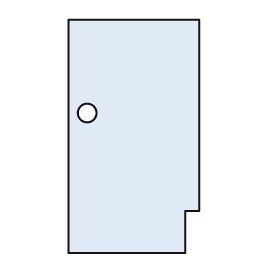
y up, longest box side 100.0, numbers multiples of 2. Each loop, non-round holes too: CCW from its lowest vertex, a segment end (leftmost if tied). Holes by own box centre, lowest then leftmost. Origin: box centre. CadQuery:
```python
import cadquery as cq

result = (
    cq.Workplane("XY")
    .moveTo(-28.0, -50.0)
    .lineTo(22.0, -50.0)
    .lineTo(22.0, -32.0)
    .lineTo(28.0, -32.0)
    .lineTo(28.0, 50.0)
    .lineTo(-28.0, 50.0)
    .close()
    .moveTo(-20.0, 10.0)
    .circle(4.0)
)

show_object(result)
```